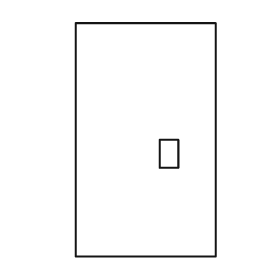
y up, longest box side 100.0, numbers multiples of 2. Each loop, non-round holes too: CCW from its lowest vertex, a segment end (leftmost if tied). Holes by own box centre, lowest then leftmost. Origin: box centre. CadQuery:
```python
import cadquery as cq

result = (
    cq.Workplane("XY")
    .moveTo(-30.0, -50.0)
    .lineTo(30.0, -50.0)
    .lineTo(30.0, 50.0)
    .lineTo(-30.0, 50.0)
    .close()
    .moveTo(6.0, -12.0)
    .lineTo(14.0, -12.0)
    .lineTo(14.0, 0.0)
    .lineTo(6.0, 0.0)
    .close()
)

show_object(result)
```